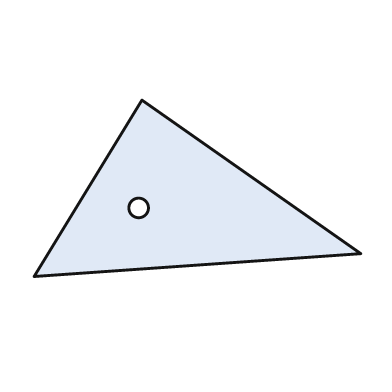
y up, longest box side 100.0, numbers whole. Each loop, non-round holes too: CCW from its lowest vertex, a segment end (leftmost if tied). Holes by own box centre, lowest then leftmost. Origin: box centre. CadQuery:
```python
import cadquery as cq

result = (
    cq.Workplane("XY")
    .moveTo(-50.0, -27.0)
    .lineTo(50.0, -20.0)
    .lineTo(-17.0, 27.0)
    .close()
    .moveTo(-18.0, -6.0)
    .circle(3.0)
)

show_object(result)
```